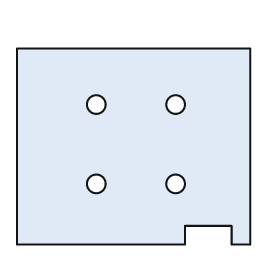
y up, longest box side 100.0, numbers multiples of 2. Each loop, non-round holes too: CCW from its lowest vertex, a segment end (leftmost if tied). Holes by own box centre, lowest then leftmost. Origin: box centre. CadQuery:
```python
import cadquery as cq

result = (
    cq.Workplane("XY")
    .moveTo(-50.0, -42.0)
    .lineTo(22.0, -42.0)
    .lineTo(22.0, -34.0)
    .lineTo(42.0, -34.0)
    .lineTo(42.0, -42.0)
    .lineTo(50.0, -42.0)
    .lineTo(50.0, 42.0)
    .lineTo(-50.0, 42.0)
    .close()
    .moveTo(-16.0, -16.0)
    .circle(4.0)
    .moveTo(18.0, -16.0)
    .circle(4.0)
    .moveTo(-16.0, 18.0)
    .circle(4.0)
    .moveTo(18.0, 18.0)
    .circle(4.0)
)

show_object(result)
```